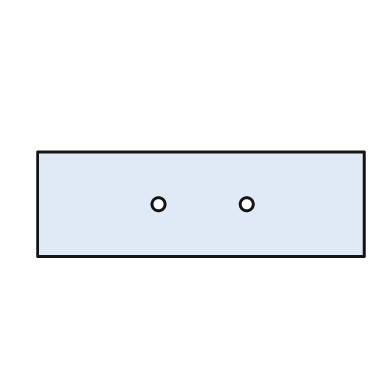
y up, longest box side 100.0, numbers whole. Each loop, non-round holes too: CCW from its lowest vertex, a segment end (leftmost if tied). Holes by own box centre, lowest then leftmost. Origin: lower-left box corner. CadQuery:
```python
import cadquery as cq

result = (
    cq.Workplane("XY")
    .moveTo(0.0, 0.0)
    .lineTo(100.0, 0.0)
    .lineTo(100.0, 32.0)
    .lineTo(0.0, 32.0)
    .close()
    .moveTo(37.0, 16.0)
    .circle(2.0)
    .moveTo(64.0, 16.0)
    .circle(2.0)
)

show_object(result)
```